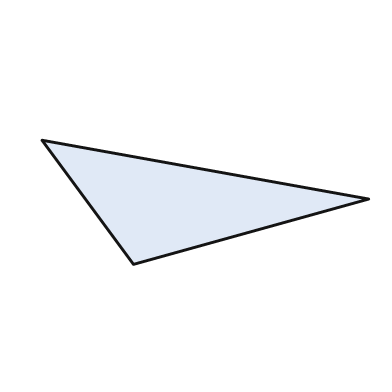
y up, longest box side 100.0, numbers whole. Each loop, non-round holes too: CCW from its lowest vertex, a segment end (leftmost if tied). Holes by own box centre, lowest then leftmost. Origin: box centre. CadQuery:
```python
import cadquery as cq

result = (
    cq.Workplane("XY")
    .moveTo(-22.0, -19.0)
    .lineTo(50.0, 1.0)
    .lineTo(-50.0, 19.0)
    .close()
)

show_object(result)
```